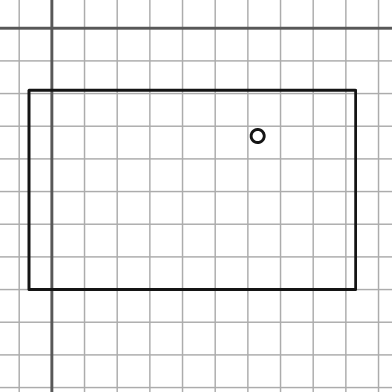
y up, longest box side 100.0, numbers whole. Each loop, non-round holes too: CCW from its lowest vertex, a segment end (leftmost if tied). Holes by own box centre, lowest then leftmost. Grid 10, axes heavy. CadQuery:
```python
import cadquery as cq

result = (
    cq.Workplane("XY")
    .moveTo(-7.0, -80.0)
    .lineTo(93.0, -80.0)
    .lineTo(93.0, -19.0)
    .lineTo(-7.0, -19.0)
    .close()
    .moveTo(63.0, -33.0)
    .circle(2.0)
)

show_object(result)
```